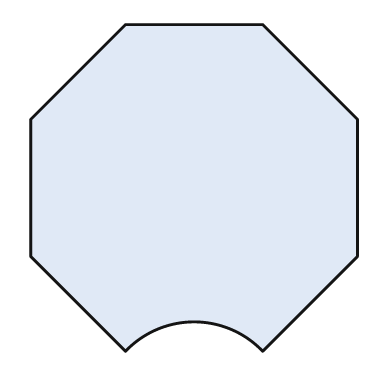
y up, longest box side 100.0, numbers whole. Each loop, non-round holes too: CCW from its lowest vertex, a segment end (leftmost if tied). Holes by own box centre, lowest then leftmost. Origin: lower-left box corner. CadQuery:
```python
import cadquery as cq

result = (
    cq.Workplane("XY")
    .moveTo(29.0, 0.0)
    .threePointArc((50.0, 9.0), (71.0, 0.0))
    .lineTo(100.0, 29.0)
    .lineTo(100.0, 71.0)
    .lineTo(71.0, 100.0)
    .lineTo(29.0, 100.0)
    .lineTo(0.0, 71.0)
    .lineTo(0.0, 29.0)
    .close()
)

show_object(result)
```